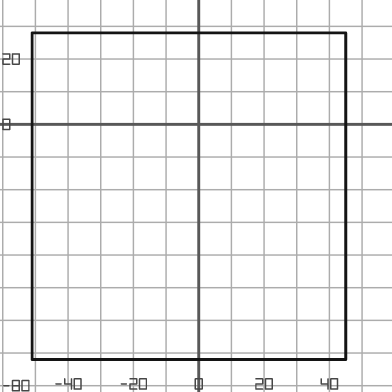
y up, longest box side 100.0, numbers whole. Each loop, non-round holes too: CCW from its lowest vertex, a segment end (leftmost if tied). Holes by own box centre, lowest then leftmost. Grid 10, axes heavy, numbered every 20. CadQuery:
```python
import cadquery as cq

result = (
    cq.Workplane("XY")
    .moveTo(-51.0, -72.0)
    .lineTo(45.0, -72.0)
    .lineTo(45.0, 28.0)
    .lineTo(-51.0, 28.0)
    .close()
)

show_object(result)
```